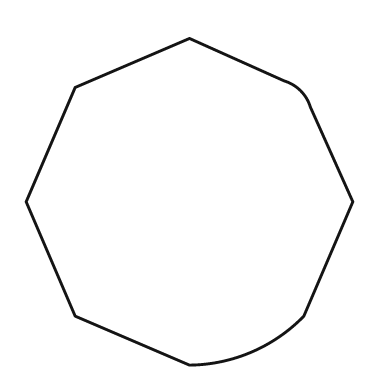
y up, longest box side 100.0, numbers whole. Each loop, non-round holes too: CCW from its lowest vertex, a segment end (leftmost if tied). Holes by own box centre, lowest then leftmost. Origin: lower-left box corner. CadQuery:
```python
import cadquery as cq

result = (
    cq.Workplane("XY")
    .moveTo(50.0, 0.0)
    .threePointArc((69.0, 4.0), (85.0, 15.0))
    .lineTo(100.0, 50.0)
    .lineTo(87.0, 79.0)
    .threePointArc((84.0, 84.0), (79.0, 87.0))
    .lineTo(50.0, 100.0)
    .lineTo(15.0, 85.0)
    .lineTo(0.0, 50.0)
    .lineTo(15.0, 15.0)
    .close()
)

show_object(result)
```